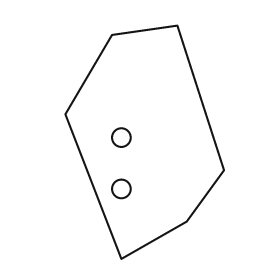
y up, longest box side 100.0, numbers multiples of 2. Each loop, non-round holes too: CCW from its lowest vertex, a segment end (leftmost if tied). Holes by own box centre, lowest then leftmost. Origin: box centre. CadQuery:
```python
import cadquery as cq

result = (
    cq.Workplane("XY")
    .moveTo(-10.0, -50.0)
    .lineTo(18.0, -34.0)
    .lineTo(34.0, -12.0)
    .lineTo(14.0, 50.0)
    .lineTo(-14.0, 46.0)
    .lineTo(-34.0, 12.0)
    .close()
    .moveTo(-10.0, -20.0)
    .circle(4.0)
    .moveTo(-10.0, 2.0)
    .circle(4.0)
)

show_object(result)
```